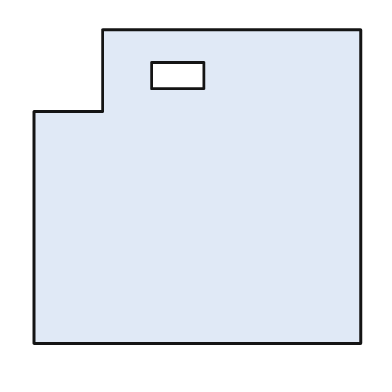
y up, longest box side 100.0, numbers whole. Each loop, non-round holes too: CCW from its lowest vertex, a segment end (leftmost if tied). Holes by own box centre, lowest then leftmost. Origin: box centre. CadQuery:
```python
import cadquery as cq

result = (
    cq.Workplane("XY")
    .moveTo(-50.0, -48.0)
    .lineTo(50.0, -48.0)
    .lineTo(50.0, 48.0)
    .lineTo(-29.0, 48.0)
    .lineTo(-29.0, 23.0)
    .lineTo(-50.0, 23.0)
    .close()
    .moveTo(-14.0, 30.0)
    .lineTo(2.0, 30.0)
    .lineTo(2.0, 38.0)
    .lineTo(-14.0, 38.0)
    .close()
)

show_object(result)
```